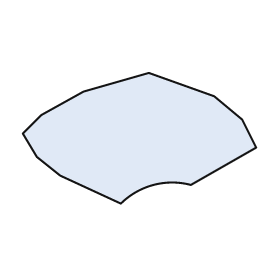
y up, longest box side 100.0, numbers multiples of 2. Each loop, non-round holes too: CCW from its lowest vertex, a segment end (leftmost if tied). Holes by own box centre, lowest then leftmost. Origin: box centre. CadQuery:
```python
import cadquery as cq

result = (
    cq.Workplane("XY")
    .moveTo(-8.0, -28.0)
    .threePointArc((6.0, -20.0), (22.0, -20.0))
    .lineTo(50.0, -4.0)
    .lineTo(44.0, 8.0)
    .lineTo(32.0, 18.0)
    .lineTo(4.0, 28.0)
    .lineTo(-24.0, 20.0)
    .lineTo(-42.0, 10.0)
    .lineTo(-50.0, 2.0)
    .lineTo(-44.0, -8.0)
    .lineTo(-34.0, -16.0)
    .close()
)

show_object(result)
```